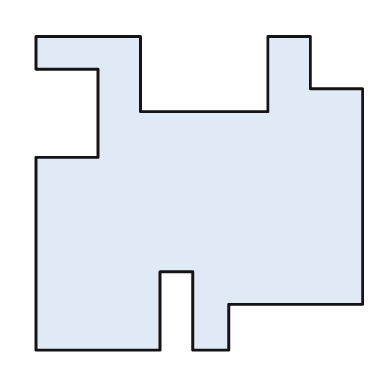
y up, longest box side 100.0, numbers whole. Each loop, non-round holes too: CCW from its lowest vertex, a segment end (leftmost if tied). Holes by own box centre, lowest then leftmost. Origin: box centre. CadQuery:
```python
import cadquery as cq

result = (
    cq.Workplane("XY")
    .moveTo(-50.0, -48.0)
    .lineTo(-12.0, -48.0)
    .lineTo(-12.0, -24.0)
    .lineTo(-2.0, -24.0)
    .lineTo(-2.0, -48.0)
    .lineTo(9.0, -48.0)
    .lineTo(9.0, -34.0)
    .lineTo(50.0, -34.0)
    .lineTo(50.0, 32.0)
    .lineTo(34.0, 32.0)
    .lineTo(34.0, 48.0)
    .lineTo(21.0, 48.0)
    .lineTo(21.0, 25.0)
    .lineTo(-18.0, 25.0)
    .lineTo(-18.0, 48.0)
    .lineTo(-50.0, 48.0)
    .lineTo(-50.0, 38.0)
    .lineTo(-31.0, 38.0)
    .lineTo(-31.0, 11.0)
    .lineTo(-50.0, 11.0)
    .close()
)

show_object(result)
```